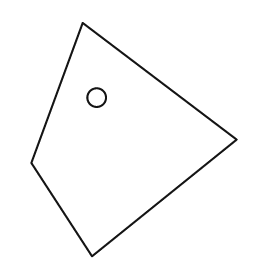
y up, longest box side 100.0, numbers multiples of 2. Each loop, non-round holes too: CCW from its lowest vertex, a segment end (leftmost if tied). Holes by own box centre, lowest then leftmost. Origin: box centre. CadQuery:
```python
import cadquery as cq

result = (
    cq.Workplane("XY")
    .moveTo(-18.0, -50.0)
    .lineTo(44.0, 0.0)
    .lineTo(-22.0, 50.0)
    .lineTo(-44.0, -10.0)
    .close()
    .moveTo(-16.0, 18.0)
    .circle(4.0)
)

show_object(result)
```